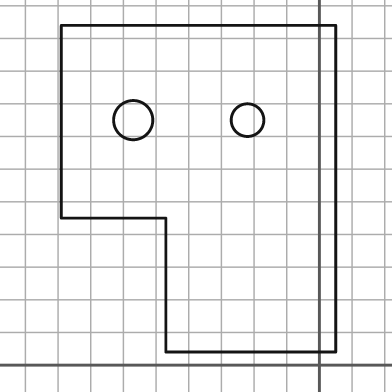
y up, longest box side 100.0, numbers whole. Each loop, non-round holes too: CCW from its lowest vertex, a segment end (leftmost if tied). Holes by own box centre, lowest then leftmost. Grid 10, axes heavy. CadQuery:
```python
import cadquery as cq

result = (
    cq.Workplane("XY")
    .moveTo(-47.0, 4.0)
    .lineTo(5.0, 4.0)
    .lineTo(5.0, 104.0)
    .lineTo(-79.0, 104.0)
    .lineTo(-79.0, 45.0)
    .lineTo(-47.0, 45.0)
    .close()
    .moveTo(-57.0, 75.0)
    .circle(6.0)
    .moveTo(-22.0, 75.0)
    .circle(5.0)
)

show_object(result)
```